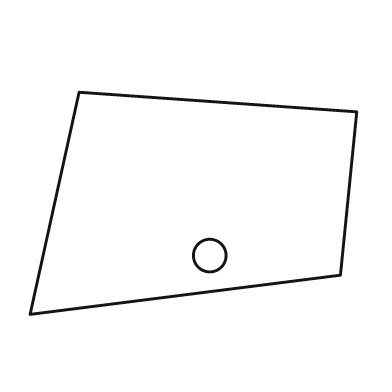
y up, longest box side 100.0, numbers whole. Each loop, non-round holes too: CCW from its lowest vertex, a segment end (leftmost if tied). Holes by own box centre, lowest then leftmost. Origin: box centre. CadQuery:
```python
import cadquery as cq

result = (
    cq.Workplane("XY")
    .moveTo(-50.0, -34.0)
    .lineTo(45.0, -22.0)
    .lineTo(50.0, 28.0)
    .lineTo(-35.0, 34.0)
    .close()
    .moveTo(5.0, -16.0)
    .circle(5.0)
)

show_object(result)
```